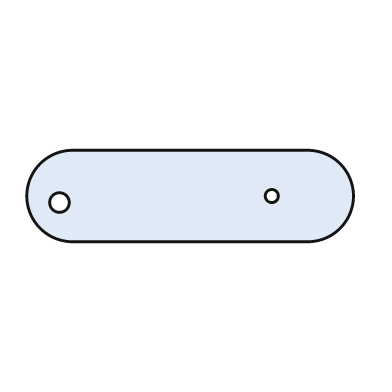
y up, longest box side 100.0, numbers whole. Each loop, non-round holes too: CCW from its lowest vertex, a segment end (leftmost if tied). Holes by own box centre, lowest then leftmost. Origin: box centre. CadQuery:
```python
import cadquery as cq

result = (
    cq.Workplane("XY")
    .moveTo(-36.0, -14.0)
    .lineTo(36.0, -14.0)
    .threePointArc((50.0, 0.0), (36.0, 14.0))
    .lineTo(-36.0, 14.0)
    .threePointArc((-50.0, 0.0), (-36.0, -14.0))
    .close()
    .moveTo(-40.0, -2.0)
    .circle(3.0)
    .moveTo(25.0, 0.0)
    .circle(2.0)
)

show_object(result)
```